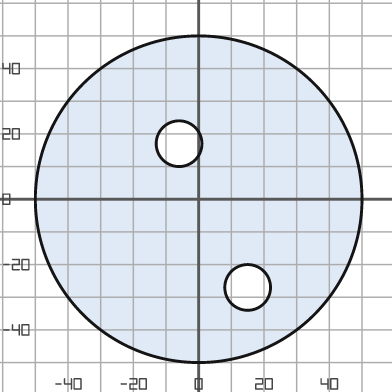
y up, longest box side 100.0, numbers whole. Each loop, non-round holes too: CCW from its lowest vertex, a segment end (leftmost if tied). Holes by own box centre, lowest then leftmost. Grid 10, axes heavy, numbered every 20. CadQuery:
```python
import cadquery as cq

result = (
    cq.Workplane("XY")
    .moveTo(0.0, 0.0)
    .circle(50.0)
    .moveTo(15.0, -27.0)
    .circle(7.0)
    .moveTo(-6.0, 17.0)
    .circle(7.0)
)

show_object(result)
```